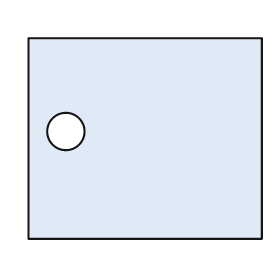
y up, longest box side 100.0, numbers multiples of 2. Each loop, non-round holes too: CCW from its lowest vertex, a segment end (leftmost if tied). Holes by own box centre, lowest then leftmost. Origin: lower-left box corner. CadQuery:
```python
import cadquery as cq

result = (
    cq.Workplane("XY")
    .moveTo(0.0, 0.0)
    .lineTo(100.0, 0.0)
    .lineTo(100.0, 86.0)
    .lineTo(0.0, 86.0)
    .close()
    .moveTo(16.0, 46.0)
    .circle(8.0)
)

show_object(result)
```